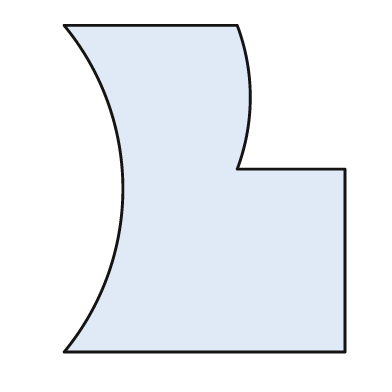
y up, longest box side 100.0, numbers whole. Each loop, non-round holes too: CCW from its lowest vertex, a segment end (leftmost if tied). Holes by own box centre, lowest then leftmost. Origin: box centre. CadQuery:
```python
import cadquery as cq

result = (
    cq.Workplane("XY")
    .moveTo(-43.0, -50.0)
    .lineTo(43.0, -50.0)
    .lineTo(43.0, 6.0)
    .lineTo(10.0, 6.0)
    .threePointArc((14.0, 28.0), (10.0, 50.0))
    .lineTo(-43.0, 50.0)
    .threePointArc((-25.0, 0.0), (-43.0, -50.0))
    .close()
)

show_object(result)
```